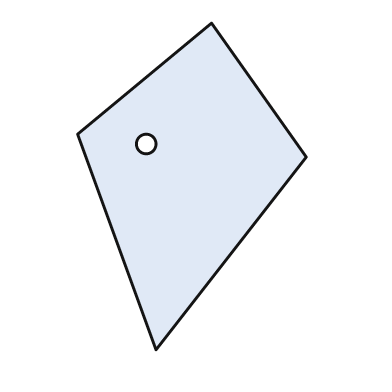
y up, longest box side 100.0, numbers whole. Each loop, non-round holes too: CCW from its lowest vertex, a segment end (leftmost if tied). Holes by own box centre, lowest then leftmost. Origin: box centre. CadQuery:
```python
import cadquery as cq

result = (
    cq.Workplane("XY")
    .moveTo(-11.0, -50.0)
    .lineTo(35.0, 9.0)
    .lineTo(6.0, 50.0)
    .lineTo(-35.0, 16.0)
    .close()
    .moveTo(-14.0, 13.0)
    .circle(3.0)
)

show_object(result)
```